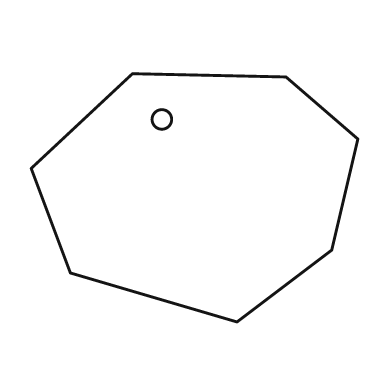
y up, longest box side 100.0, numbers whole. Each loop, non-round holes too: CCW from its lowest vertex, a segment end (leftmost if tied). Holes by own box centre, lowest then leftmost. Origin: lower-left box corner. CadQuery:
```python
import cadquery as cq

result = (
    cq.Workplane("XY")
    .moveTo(63.0, 0.0)
    .lineTo(92.0, 22.0)
    .lineTo(100.0, 56.0)
    .lineTo(78.0, 75.0)
    .lineTo(31.0, 76.0)
    .lineTo(0.0, 47.0)
    .lineTo(12.0, 15.0)
    .close()
    .moveTo(40.0, 62.0)
    .circle(3.0)
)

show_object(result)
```